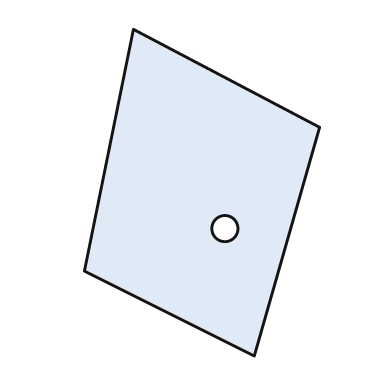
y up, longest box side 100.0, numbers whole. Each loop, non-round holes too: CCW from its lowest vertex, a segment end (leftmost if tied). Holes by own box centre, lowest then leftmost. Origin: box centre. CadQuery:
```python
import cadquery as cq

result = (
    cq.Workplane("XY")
    .moveTo(16.0, -50.0)
    .lineTo(36.0, 20.0)
    .lineTo(-21.0, 50.0)
    .lineTo(-36.0, -24.0)
    .close()
    .moveTo(7.0, -11.0)
    .circle(4.0)
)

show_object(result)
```